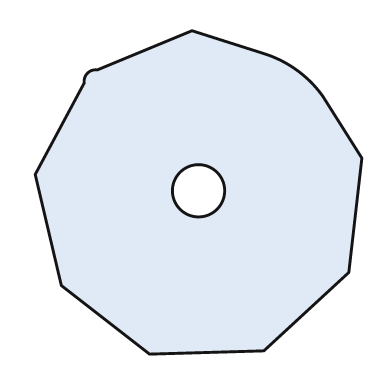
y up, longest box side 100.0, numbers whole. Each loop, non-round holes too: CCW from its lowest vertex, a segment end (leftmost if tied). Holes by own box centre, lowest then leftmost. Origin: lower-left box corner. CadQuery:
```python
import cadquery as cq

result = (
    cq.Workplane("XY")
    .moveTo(35.0, 0.0)
    .lineTo(70.0, 1.0)
    .lineTo(96.0, 25.0)
    .lineTo(100.0, 60.0)
    .lineTo(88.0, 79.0)
    .threePointArc((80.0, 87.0), (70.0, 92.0))
    .lineTo(48.0, 99.0)
    .lineTo(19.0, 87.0)
    .threePointArc((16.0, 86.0), (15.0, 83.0))
    .lineTo(0.0, 55.0)
    .lineTo(8.0, 21.0)
    .close()
    .moveTo(50.0, 50.0)
    .circle(8.0)
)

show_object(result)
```